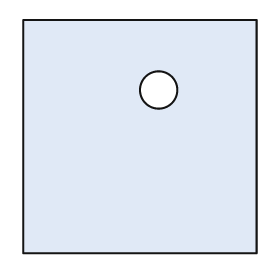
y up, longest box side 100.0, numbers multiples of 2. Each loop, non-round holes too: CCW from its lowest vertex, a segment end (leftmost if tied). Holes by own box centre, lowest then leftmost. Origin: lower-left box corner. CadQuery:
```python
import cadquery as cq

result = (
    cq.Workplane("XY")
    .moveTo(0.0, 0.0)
    .lineTo(100.0, 0.0)
    .lineTo(100.0, 100.0)
    .lineTo(0.0, 100.0)
    .close()
    .moveTo(58.0, 70.0)
    .circle(8.0)
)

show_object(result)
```